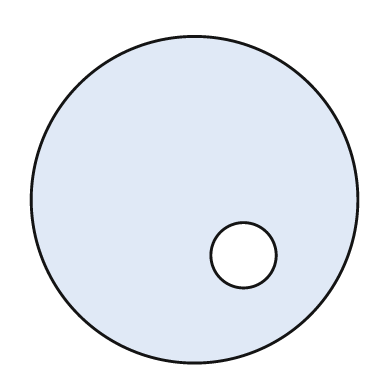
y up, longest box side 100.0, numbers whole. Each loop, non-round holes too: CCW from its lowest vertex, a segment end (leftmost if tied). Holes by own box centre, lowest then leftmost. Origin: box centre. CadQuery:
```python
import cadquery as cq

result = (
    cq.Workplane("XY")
    .moveTo(0.0, 0.0)
    .circle(50.0)
    .moveTo(15.0, -17.0)
    .circle(10.0)
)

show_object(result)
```